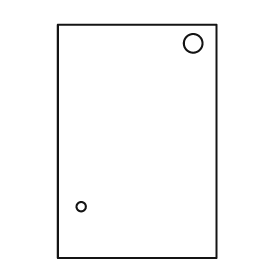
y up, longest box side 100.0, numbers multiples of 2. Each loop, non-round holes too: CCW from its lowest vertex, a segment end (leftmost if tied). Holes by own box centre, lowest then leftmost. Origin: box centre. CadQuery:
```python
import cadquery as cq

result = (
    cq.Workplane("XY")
    .moveTo(-34.0, -50.0)
    .lineTo(34.0, -50.0)
    .lineTo(34.0, 50.0)
    .lineTo(-34.0, 50.0)
    .close()
    .moveTo(-24.0, -28.0)
    .circle(2.0)
    .moveTo(24.0, 42.0)
    .circle(4.0)
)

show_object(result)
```